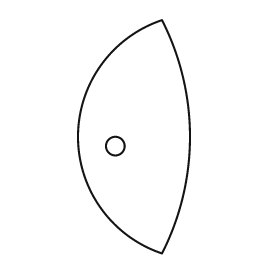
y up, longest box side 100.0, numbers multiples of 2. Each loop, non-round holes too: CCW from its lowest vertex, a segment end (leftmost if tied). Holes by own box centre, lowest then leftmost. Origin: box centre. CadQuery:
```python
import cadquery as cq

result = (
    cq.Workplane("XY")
    .moveTo(12.0, -50.0)
    .threePointArc((24.0, 0.0), (12.0, 50.0))
    .threePointArc((-24.0, 0.0), (12.0, -50.0))
    .close()
    .moveTo(-8.0, -4.0)
    .circle(4.0)
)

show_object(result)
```